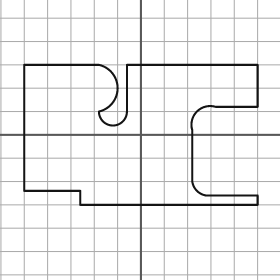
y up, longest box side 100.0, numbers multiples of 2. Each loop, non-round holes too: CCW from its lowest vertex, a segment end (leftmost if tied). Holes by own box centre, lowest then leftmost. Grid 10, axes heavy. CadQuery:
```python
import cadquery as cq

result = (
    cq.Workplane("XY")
    .moveTo(-26.0, -30.0)
    .lineTo(50.0, -30.0)
    .lineTo(50.0, -26.0)
    .lineTo(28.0, -26.0)
    .threePointArc((24.0, -24.0), (22.0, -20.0))
    .lineTo(22.0, 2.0)
    .threePointArc((24.0, 10.0), (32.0, 12.0))
    .lineTo(50.0, 12.0)
    .lineTo(50.0, 30.0)
    .lineTo(-6.0, 30.0)
    .lineTo(-6.0, 10.0)
    .threePointArc((-12.0, 4.0), (-18.0, 10.0))
    .threePointArc((-10.0, 20.0), (-18.0, 30.0))
    .lineTo(-50.0, 30.0)
    .lineTo(-50.0, -24.0)
    .lineTo(-26.0, -24.0)
    .close()
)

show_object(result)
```